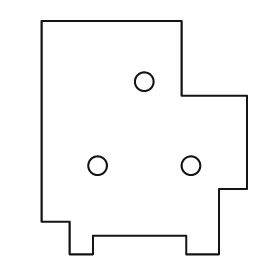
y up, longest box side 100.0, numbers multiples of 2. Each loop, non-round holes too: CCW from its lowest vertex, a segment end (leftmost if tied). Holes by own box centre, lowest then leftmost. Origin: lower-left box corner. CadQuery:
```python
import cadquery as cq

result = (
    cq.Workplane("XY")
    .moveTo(12.0, 0.0)
    .lineTo(22.0, 0.0)
    .lineTo(22.0, 8.0)
    .lineTo(62.0, 8.0)
    .lineTo(62.0, 0.0)
    .lineTo(76.0, 0.0)
    .lineTo(76.0, 28.0)
    .lineTo(88.0, 28.0)
    .lineTo(88.0, 68.0)
    .lineTo(60.0, 68.0)
    .lineTo(60.0, 100.0)
    .lineTo(0.0, 100.0)
    .lineTo(0.0, 14.0)
    .lineTo(12.0, 14.0)
    .close()
    .moveTo(24.0, 38.0)
    .circle(4.0)
    .moveTo(64.0, 38.0)
    .circle(4.0)
    .moveTo(44.0, 74.0)
    .circle(4.0)
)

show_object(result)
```